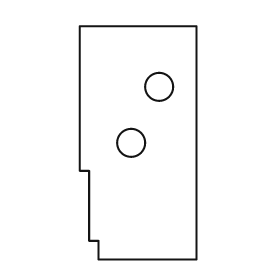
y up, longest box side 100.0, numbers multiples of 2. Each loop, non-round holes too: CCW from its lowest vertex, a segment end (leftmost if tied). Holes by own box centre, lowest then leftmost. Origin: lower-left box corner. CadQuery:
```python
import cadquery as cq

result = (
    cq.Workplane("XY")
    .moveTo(8.0, 0.0)
    .lineTo(50.0, 0.0)
    .lineTo(50.0, 100.0)
    .lineTo(0.0, 100.0)
    .lineTo(0.0, 38.0)
    .lineTo(4.0, 38.0)
    .lineTo(4.0, 8.0)
    .lineTo(8.0, 8.0)
    .close()
    .moveTo(22.0, 50.0)
    .circle(6.0)
    .moveTo(34.0, 74.0)
    .circle(6.0)
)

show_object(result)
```